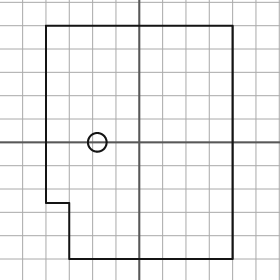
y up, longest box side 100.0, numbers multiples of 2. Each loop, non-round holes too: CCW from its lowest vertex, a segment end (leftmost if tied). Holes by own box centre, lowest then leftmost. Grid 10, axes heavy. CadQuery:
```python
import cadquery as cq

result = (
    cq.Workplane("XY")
    .moveTo(-30.0, -50.0)
    .lineTo(40.0, -50.0)
    .lineTo(40.0, 50.0)
    .lineTo(-40.0, 50.0)
    .lineTo(-40.0, -26.0)
    .lineTo(-30.0, -26.0)
    .close()
    .moveTo(-18.0, 0.0)
    .circle(4.0)
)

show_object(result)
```